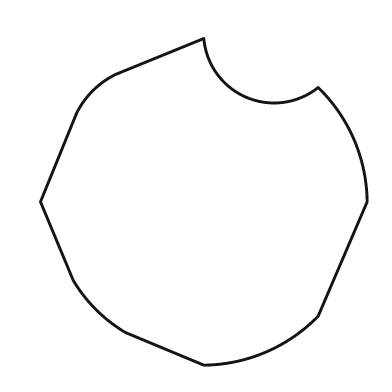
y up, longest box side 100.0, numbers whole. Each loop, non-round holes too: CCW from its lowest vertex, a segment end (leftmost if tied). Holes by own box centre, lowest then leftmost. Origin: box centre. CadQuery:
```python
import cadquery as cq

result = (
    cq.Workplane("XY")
    .moveTo(0.0, -50.0)
    .threePointArc((19.0, -46.0), (35.0, -35.0))
    .lineTo(50.0, 0.0)
    .threePointArc((46.0, 19.0), (35.0, 35.0))
    .threePointArc((13.0, 32.0), (0.0, 50.0))
    .lineTo(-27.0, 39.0)
    .threePointArc((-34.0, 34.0), (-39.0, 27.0))
    .lineTo(-50.0, 0.0)
    .lineTo(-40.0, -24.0)
    .threePointArc((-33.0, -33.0), (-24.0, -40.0))
    .close()
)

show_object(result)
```